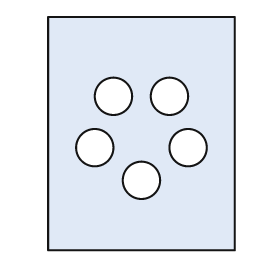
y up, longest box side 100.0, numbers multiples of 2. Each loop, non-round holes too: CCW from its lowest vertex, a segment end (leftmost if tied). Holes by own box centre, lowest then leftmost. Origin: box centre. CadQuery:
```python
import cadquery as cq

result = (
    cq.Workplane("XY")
    .moveTo(-40.0, -50.0)
    .lineTo(40.0, -50.0)
    .lineTo(40.0, 50.0)
    .lineTo(-40.0, 50.0)
    .close()
    .moveTo(0.0, -20.0)
    .circle(8.0)
    .moveTo(-20.0, -6.0)
    .circle(8.0)
    .moveTo(20.0, -6.0)
    .circle(8.0)
    .moveTo(-12.0, 16.0)
    .circle(8.0)
    .moveTo(12.0, 16.0)
    .circle(8.0)
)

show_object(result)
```